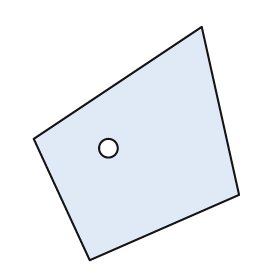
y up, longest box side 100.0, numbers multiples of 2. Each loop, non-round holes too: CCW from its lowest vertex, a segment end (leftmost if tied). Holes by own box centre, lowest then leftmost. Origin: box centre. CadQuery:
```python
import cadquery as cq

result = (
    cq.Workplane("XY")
    .moveTo(-20.0, -50.0)
    .lineTo(44.0, -22.0)
    .lineTo(28.0, 50.0)
    .lineTo(-44.0, 2.0)
    .close()
    .moveTo(-12.0, -2.0)
    .circle(4.0)
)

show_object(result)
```